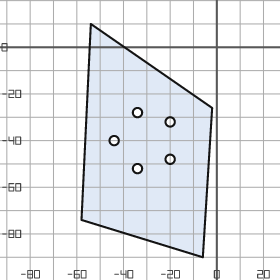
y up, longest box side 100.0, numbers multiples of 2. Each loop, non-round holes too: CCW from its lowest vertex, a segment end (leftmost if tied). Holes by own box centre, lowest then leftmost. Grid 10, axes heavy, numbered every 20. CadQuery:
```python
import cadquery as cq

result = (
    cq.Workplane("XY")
    .moveTo(-6.0, -90.0)
    .lineTo(-2.0, -26.0)
    .lineTo(-54.0, 10.0)
    .lineTo(-58.0, -74.0)
    .close()
    .moveTo(-34.0, -52.0)
    .circle(2.0)
    .moveTo(-20.0, -48.0)
    .circle(2.0)
    .moveTo(-44.0, -40.0)
    .circle(2.0)
    .moveTo(-20.0, -32.0)
    .circle(2.0)
    .moveTo(-34.0, -28.0)
    .circle(2.0)
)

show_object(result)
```